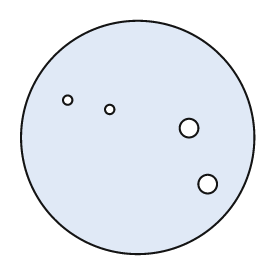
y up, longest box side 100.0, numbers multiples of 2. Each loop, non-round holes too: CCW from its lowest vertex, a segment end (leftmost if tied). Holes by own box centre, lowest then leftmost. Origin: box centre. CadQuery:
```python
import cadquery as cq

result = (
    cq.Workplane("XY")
    .moveTo(0.0, 0.0)
    .circle(50.0)
    .moveTo(30.0, -20.0)
    .circle(4.0)
    .moveTo(22.0, 4.0)
    .circle(4.0)
    .moveTo(-12.0, 12.0)
    .circle(2.0)
    .moveTo(-30.0, 16.0)
    .circle(2.0)
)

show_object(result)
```